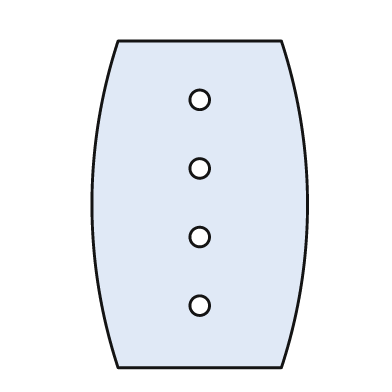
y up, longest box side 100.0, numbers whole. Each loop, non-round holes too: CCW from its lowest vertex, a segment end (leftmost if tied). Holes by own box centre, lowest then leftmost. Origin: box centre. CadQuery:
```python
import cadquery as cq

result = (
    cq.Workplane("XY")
    .moveTo(-25.0, -50.0)
    .lineTo(25.0, -50.0)
    .threePointArc((33.0, 0.0), (25.0, 50.0))
    .lineTo(-25.0, 50.0)
    .threePointArc((-33.0, 0.0), (-25.0, -50.0))
    .close()
    .moveTo(0.0, -31.0)
    .circle(3.0)
    .moveTo(0.0, -10.0)
    .circle(3.0)
    .moveTo(0.0, 11.0)
    .circle(3.0)
    .moveTo(0.0, 32.0)
    .circle(3.0)
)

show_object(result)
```